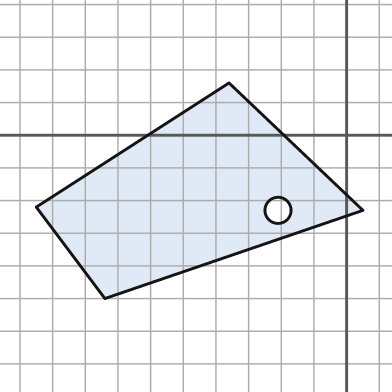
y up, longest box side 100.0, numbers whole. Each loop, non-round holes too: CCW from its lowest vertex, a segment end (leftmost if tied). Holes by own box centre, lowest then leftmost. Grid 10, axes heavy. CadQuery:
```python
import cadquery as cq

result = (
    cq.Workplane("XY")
    .moveTo(-74.0, -50.0)
    .lineTo(5.0, -23.0)
    .lineTo(-36.0, 16.0)
    .lineTo(-95.0, -22.0)
    .close()
    .moveTo(-21.0, -23.0)
    .circle(4.0)
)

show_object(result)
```